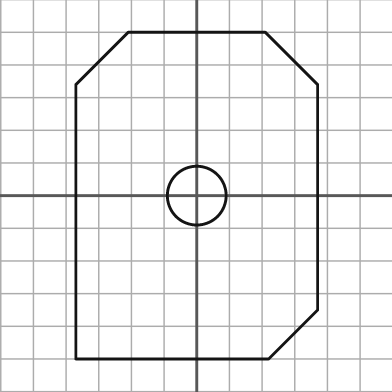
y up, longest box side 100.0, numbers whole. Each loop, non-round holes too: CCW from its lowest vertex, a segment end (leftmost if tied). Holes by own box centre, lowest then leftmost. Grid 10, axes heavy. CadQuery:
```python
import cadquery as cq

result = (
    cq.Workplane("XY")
    .moveTo(-37.0, -50.0)
    .lineTo(22.0, -50.0)
    .lineTo(37.0, -35.0)
    .lineTo(37.0, 34.0)
    .lineTo(21.0, 50.0)
    .lineTo(-21.0, 50.0)
    .lineTo(-37.0, 34.0)
    .close()
    .moveTo(0.0, 0.0)
    .circle(9.0)
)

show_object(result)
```